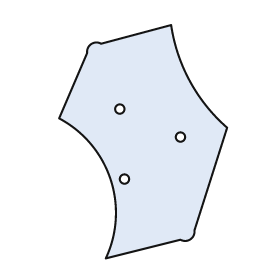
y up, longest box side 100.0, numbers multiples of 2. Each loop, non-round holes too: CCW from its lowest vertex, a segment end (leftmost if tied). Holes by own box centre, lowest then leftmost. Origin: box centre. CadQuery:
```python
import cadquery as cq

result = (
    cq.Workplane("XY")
    .moveTo(-16.0, -50.0)
    .lineTo(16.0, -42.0)
    .threePointArc((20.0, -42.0), (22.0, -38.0))
    .lineTo(36.0, 6.0)
    .threePointArc((20.0, 26.0), (12.0, 50.0))
    .lineTo(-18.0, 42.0)
    .threePointArc((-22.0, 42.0), (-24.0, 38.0))
    .lineTo(-36.0, 10.0)
    .threePointArc((-14.0, -16.0), (-16.0, -50.0))
    .close()
    .moveTo(-8.0, -16.0)
    .circle(2.0)
    .moveTo(16.0, 2.0)
    .circle(2.0)
    .moveTo(-10.0, 14.0)
    .circle(2.0)
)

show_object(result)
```